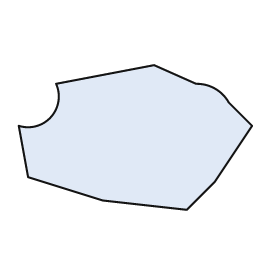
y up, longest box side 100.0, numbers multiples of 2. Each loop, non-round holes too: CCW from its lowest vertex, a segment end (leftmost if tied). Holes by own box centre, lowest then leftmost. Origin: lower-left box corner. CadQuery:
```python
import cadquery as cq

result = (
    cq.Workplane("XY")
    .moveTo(72.0, 0.0)
    .lineTo(84.0, 12.0)
    .lineTo(100.0, 36.0)
    .lineTo(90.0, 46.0)
    .threePointArc((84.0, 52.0), (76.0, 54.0))
    .lineTo(58.0, 62.0)
    .lineTo(16.0, 54.0)
    .threePointArc((14.0, 40.0), (0.0, 36.0))
    .lineTo(4.0, 14.0)
    .lineTo(36.0, 4.0)
    .close()
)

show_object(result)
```